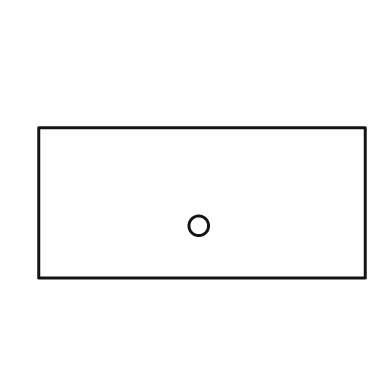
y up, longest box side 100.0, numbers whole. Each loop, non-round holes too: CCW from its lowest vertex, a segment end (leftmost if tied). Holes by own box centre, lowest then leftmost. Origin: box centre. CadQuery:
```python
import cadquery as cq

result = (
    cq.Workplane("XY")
    .moveTo(-50.0, -23.0)
    .lineTo(50.0, -23.0)
    .lineTo(50.0, 23.0)
    .lineTo(-50.0, 23.0)
    .close()
    .moveTo(-1.0, -7.0)
    .circle(3.0)
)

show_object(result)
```